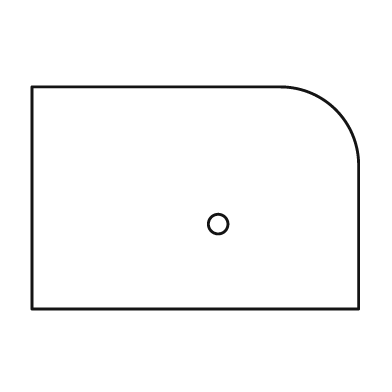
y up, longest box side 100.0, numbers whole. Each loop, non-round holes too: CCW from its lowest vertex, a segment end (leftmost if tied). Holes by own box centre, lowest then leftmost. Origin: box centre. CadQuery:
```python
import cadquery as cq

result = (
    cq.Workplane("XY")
    .moveTo(-50.0, -34.0)
    .lineTo(50.0, -34.0)
    .lineTo(50.0, 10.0)
    .threePointArc((43.0, 27.0), (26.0, 34.0))
    .lineTo(-50.0, 34.0)
    .close()
    .moveTo(7.0, -8.0)
    .circle(3.0)
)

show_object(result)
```